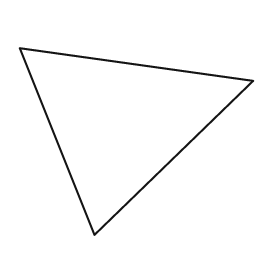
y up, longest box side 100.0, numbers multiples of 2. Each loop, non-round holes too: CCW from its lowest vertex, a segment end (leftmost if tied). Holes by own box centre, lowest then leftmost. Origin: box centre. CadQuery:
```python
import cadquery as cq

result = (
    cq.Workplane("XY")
    .moveTo(-18.0, -40.0)
    .lineTo(50.0, 26.0)
    .lineTo(-50.0, 40.0)
    .close()
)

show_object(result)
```